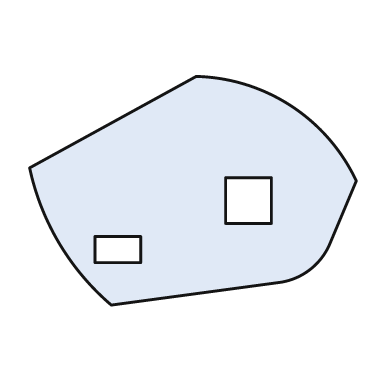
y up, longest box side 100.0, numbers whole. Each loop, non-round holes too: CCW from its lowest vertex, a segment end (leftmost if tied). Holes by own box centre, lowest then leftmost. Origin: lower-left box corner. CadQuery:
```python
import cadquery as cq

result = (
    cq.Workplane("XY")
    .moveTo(25.0, 0.0)
    .lineTo(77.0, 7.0)
    .threePointArc((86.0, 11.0), (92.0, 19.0))
    .lineTo(100.0, 38.0)
    .threePointArc((80.0, 61.0), (51.0, 70.0))
    .lineTo(0.0, 42.0)
    .threePointArc((9.0, 19.0), (25.0, 0.0))
    .close()
    .moveTo(20.0, 13.0)
    .lineTo(34.0, 13.0)
    .lineTo(34.0, 21.0)
    .lineTo(20.0, 21.0)
    .close()
    .moveTo(60.0, 25.0)
    .lineTo(74.0, 25.0)
    .lineTo(74.0, 39.0)
    .lineTo(60.0, 39.0)
    .close()
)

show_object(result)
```